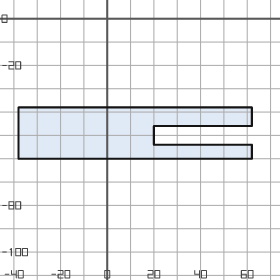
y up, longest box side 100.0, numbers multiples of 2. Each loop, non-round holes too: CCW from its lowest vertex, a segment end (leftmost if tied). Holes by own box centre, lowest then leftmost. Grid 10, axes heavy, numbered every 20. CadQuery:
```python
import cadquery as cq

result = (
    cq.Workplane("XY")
    .moveTo(-38.0, -60.0)
    .lineTo(62.0, -60.0)
    .lineTo(62.0, -54.0)
    .lineTo(20.0, -54.0)
    .lineTo(20.0, -46.0)
    .lineTo(62.0, -46.0)
    .lineTo(62.0, -38.0)
    .lineTo(-38.0, -38.0)
    .close()
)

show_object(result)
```